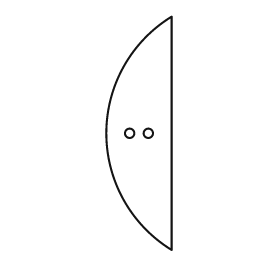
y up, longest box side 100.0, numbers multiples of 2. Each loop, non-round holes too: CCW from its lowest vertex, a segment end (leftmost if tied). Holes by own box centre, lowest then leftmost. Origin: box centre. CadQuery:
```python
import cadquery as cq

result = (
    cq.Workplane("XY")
    .moveTo(14.0, -50.0)
    .lineTo(14.0, 50.0)
    .threePointArc((-14.0, 0.0), (14.0, -50.0))
    .close()
    .moveTo(-4.0, 0.0)
    .circle(2.0)
    .moveTo(4.0, 0.0)
    .circle(2.0)
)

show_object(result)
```